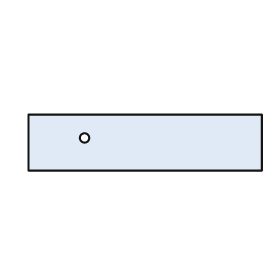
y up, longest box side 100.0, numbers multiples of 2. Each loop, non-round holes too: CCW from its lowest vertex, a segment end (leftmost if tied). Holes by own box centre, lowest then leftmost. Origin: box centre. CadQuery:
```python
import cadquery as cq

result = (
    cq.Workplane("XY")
    .moveTo(-50.0, -12.0)
    .lineTo(50.0, -12.0)
    .lineTo(50.0, 12.0)
    .lineTo(-50.0, 12.0)
    .close()
    .moveTo(-26.0, 2.0)
    .circle(2.0)
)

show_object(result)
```